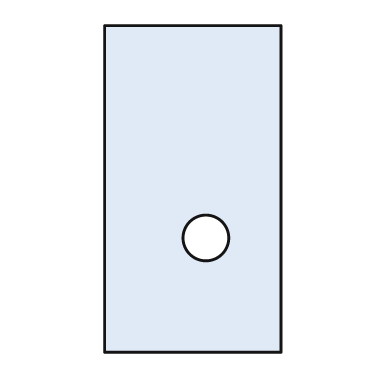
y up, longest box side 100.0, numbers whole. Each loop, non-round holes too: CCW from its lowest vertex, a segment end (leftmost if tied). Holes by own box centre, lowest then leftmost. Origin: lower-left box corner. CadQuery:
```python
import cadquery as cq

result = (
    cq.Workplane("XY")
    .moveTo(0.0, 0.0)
    .lineTo(54.0, 0.0)
    .lineTo(54.0, 100.0)
    .lineTo(0.0, 100.0)
    .close()
    .moveTo(31.0, 35.0)
    .circle(7.0)
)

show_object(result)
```